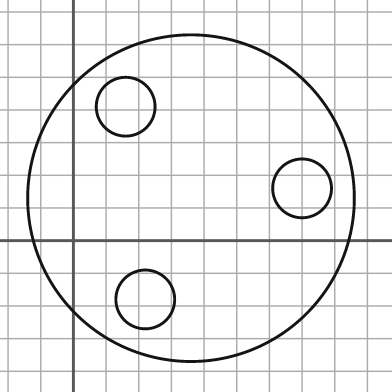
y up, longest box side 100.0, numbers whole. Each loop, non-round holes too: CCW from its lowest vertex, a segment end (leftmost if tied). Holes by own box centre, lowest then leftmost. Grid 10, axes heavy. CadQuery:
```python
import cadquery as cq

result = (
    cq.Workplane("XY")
    .moveTo(36.0, 13.0)
    .circle(50.0)
    .moveTo(22.0, -18.0)
    .circle(9.0)
    .moveTo(70.0, 16.0)
    .circle(9.0)
    .moveTo(16.0, 41.0)
    .circle(9.0)
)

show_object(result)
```